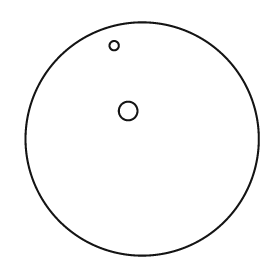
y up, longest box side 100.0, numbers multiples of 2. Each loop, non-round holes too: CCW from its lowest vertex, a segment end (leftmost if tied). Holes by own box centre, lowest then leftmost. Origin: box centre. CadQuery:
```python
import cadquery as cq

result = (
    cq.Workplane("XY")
    .moveTo(0.0, 0.0)
    .circle(50.0)
    .moveTo(-6.0, 12.0)
    .circle(4.0)
    .moveTo(-12.0, 40.0)
    .circle(2.0)
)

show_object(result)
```